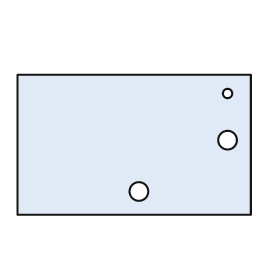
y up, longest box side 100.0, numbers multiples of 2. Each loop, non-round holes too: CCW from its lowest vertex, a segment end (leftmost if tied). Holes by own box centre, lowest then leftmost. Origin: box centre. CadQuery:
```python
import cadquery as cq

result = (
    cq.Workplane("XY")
    .moveTo(-50.0, -30.0)
    .lineTo(50.0, -30.0)
    .lineTo(50.0, 30.0)
    .lineTo(-50.0, 30.0)
    .close()
    .moveTo(2.0, -20.0)
    .circle(4.0)
    .moveTo(40.0, 2.0)
    .circle(4.0)
    .moveTo(40.0, 22.0)
    .circle(2.0)
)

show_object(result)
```